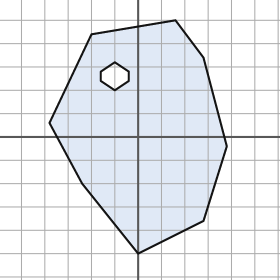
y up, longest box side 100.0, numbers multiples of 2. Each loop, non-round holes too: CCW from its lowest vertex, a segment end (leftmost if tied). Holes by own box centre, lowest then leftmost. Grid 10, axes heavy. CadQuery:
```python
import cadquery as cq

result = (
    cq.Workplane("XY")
    .moveTo(0.0, -50.0)
    .lineTo(28.0, -36.0)
    .lineTo(38.0, -4.0)
    .lineTo(28.0, 34.0)
    .lineTo(16.0, 50.0)
    .lineTo(-20.0, 44.0)
    .lineTo(-38.0, 6.0)
    .lineTo(-24.0, -20.0)
    .close()
    .moveTo(-10.0, 20.0)
    .lineTo(-4.0, 24.0)
    .lineTo(-4.0, 28.0)
    .lineTo(-10.0, 32.0)
    .lineTo(-16.0, 28.0)
    .lineTo(-16.0, 24.0)
    .close()
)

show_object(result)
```